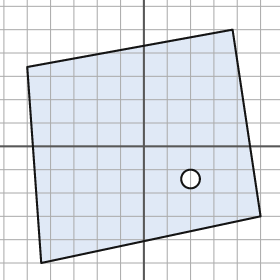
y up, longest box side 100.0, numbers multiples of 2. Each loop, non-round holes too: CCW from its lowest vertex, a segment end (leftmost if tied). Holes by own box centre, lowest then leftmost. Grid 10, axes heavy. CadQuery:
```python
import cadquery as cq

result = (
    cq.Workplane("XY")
    .moveTo(-44.0, -50.0)
    .lineTo(50.0, -30.0)
    .lineTo(38.0, 50.0)
    .lineTo(-50.0, 34.0)
    .close()
    .moveTo(20.0, -14.0)
    .circle(4.0)
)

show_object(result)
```